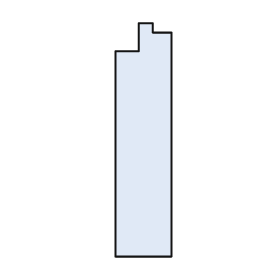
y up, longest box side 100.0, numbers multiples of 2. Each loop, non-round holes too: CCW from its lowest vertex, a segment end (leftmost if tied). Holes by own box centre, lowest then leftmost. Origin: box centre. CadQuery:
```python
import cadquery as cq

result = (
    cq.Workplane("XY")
    .moveTo(-12.0, -50.0)
    .lineTo(12.0, -50.0)
    .lineTo(12.0, 46.0)
    .lineTo(4.0, 46.0)
    .lineTo(4.0, 50.0)
    .lineTo(-2.0, 50.0)
    .lineTo(-2.0, 38.0)
    .lineTo(-12.0, 38.0)
    .close()
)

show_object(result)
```